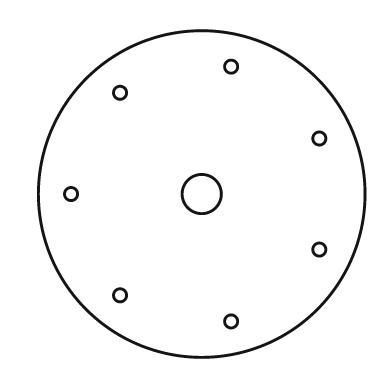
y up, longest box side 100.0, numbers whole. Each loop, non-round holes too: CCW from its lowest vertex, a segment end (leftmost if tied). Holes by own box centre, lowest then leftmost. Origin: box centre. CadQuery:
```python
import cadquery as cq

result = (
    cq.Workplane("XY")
    .moveTo(0.0, 0.0)
    .circle(50.0)
    .moveTo(9.0, -39.0)
    .circle(2.0)
    .moveTo(-25.0, -31.0)
    .circle(2.0)
    .moveTo(36.0, -17.0)
    .circle(2.0)
    .moveTo(-40.0, 0.0)
    .circle(2.0)
    .moveTo(0.0, 0.0)
    .circle(6.0)
    .moveTo(36.0, 17.0)
    .circle(2.0)
    .moveTo(-25.0, 31.0)
    .circle(2.0)
    .moveTo(9.0, 39.0)
    .circle(2.0)
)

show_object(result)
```